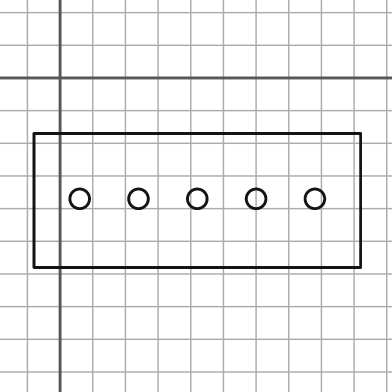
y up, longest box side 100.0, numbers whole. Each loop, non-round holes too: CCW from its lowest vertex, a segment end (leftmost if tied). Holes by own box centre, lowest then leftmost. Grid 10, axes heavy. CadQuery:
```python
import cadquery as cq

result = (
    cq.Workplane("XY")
    .moveTo(-8.0, -58.0)
    .lineTo(92.0, -58.0)
    .lineTo(92.0, -17.0)
    .lineTo(-8.0, -17.0)
    .close()
    .moveTo(6.0, -37.0)
    .circle(3.0)
    .moveTo(24.0, -37.0)
    .circle(3.0)
    .moveTo(42.0, -37.0)
    .circle(3.0)
    .moveTo(60.0, -37.0)
    .circle(3.0)
    .moveTo(78.0, -37.0)
    .circle(3.0)
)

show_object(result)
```